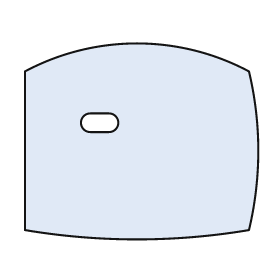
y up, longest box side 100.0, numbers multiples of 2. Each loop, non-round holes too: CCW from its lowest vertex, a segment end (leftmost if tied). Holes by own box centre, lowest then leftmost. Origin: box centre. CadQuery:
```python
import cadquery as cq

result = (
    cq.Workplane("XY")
    .moveTo(-50.0, -38.0)
    .threePointArc((-2.0, -42.0), (46.0, -38.0))
    .threePointArc((50.0, -4.0), (46.0, 30.0))
    .threePointArc((-2.0, 42.0), (-50.0, 30.0))
    .close()
    .moveTo(-22.0, 4.0)
    .lineTo(-14.0, 4.0)
    .threePointArc((-10.0, 8.0), (-14.0, 12.0))
    .lineTo(-22.0, 12.0)
    .threePointArc((-26.0, 8.0), (-22.0, 4.0))
    .close()
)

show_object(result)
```